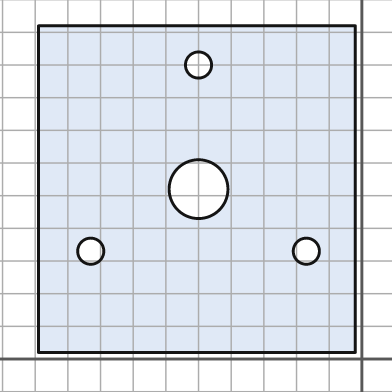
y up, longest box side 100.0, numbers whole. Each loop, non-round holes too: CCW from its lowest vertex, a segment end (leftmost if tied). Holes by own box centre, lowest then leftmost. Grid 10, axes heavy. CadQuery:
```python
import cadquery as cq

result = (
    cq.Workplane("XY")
    .moveTo(-99.0, 2.0)
    .lineTo(-2.0, 2.0)
    .lineTo(-2.0, 102.0)
    .lineTo(-99.0, 102.0)
    .close()
    .moveTo(-83.0, 33.0)
    .circle(4.0)
    .moveTo(-17.0, 33.0)
    .circle(4.0)
    .moveTo(-50.0, 52.0)
    .circle(9.0)
    .moveTo(-50.0, 90.0)
    .circle(4.0)
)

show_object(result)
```